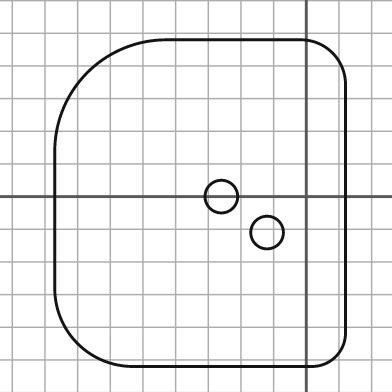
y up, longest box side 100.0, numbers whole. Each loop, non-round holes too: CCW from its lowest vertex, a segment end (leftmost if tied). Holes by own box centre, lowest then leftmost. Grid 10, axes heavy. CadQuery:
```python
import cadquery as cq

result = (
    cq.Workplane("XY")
    .moveTo(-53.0, -52.0)
    .lineTo(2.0, -52.0)
    .threePointArc((9.0, -49.0), (12.0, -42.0))
    .lineTo(12.0, 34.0)
    .threePointArc((8.0, 44.0), (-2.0, 48.0))
    .lineTo(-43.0, 48.0)
    .threePointArc((-67.0, 38.0), (-77.0, 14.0))
    .lineTo(-77.0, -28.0)
    .threePointArc((-70.0, -45.0), (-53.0, -52.0))
    .close()
    .moveTo(-12.0, -11.0)
    .circle(5.0)
    .moveTo(-26.0, 0.0)
    .circle(5.0)
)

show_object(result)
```